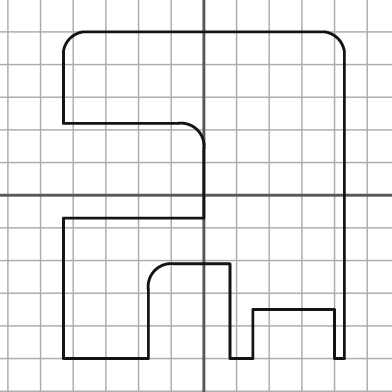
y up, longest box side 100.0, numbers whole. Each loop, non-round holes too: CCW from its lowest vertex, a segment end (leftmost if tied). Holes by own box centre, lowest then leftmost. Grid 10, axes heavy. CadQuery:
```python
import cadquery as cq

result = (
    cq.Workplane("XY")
    .moveTo(-43.0, -50.0)
    .lineTo(-17.0, -50.0)
    .lineTo(-17.0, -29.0)
    .threePointArc((-15.0, -23.0), (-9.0, -21.0))
    .lineTo(8.0, -21.0)
    .lineTo(8.0, -50.0)
    .lineTo(15.0, -50.0)
    .lineTo(15.0, -35.0)
    .lineTo(40.0, -35.0)
    .lineTo(40.0, -50.0)
    .lineTo(43.0, -50.0)
    .lineTo(43.0, 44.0)
    .threePointArc((41.0, 48.0), (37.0, 50.0))
    .lineTo(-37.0, 50.0)
    .threePointArc((-41.0, 48.0), (-43.0, 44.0))
    .lineTo(-43.0, 22.0)
    .lineTo(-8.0, 22.0)
    .threePointArc((-2.0, 20.0), (0.0, 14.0))
    .lineTo(0.0, -7.0)
    .lineTo(-43.0, -7.0)
    .close()
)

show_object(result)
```